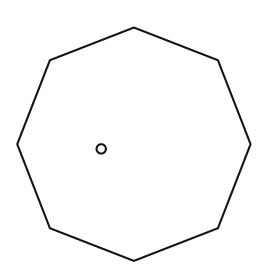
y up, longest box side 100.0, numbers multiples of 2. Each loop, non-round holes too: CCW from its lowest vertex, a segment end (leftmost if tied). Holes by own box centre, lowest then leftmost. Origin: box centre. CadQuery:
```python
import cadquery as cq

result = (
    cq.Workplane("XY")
    .moveTo(0.0, -50.0)
    .lineTo(36.0, -36.0)
    .lineTo(50.0, 0.0)
    .lineTo(36.0, 36.0)
    .lineTo(0.0, 50.0)
    .lineTo(-36.0, 36.0)
    .lineTo(-50.0, 0.0)
    .lineTo(-36.0, -36.0)
    .close()
    .moveTo(-14.0, -2.0)
    .circle(2.0)
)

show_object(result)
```